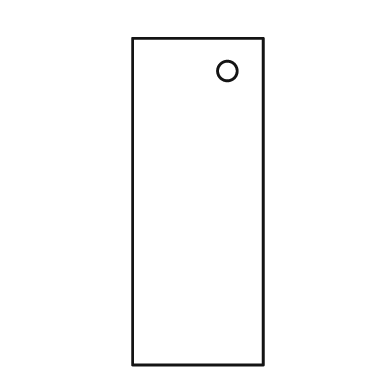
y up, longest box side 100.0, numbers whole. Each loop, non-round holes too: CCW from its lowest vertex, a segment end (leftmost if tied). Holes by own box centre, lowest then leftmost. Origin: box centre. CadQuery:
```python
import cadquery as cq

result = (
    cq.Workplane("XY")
    .moveTo(-20.0, -50.0)
    .lineTo(20.0, -50.0)
    .lineTo(20.0, 50.0)
    .lineTo(-20.0, 50.0)
    .close()
    .moveTo(9.0, 40.0)
    .circle(3.0)
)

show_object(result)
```